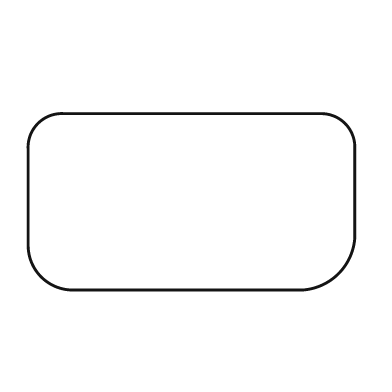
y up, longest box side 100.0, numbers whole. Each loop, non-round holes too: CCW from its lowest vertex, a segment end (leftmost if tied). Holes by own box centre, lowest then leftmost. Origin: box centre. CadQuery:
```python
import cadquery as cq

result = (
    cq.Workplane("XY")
    .moveTo(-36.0, -27.0)
    .lineTo(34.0, -27.0)
    .threePointArc((45.0, -22.0), (50.0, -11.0))
    .lineTo(50.0, 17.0)
    .threePointArc((47.0, 24.0), (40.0, 27.0))
    .lineTo(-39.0, 27.0)
    .threePointArc((-47.0, 24.0), (-50.0, 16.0))
    .lineTo(-50.0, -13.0)
    .threePointArc((-46.0, -23.0), (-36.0, -27.0))
    .close()
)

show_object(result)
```